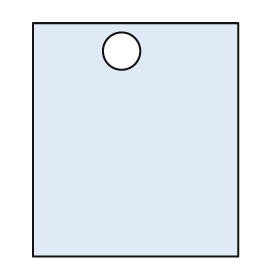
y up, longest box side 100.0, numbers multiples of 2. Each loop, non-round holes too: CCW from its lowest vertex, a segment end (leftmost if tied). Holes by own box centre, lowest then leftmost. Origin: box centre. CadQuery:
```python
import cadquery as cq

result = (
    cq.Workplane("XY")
    .moveTo(-44.0, -50.0)
    .lineTo(44.0, -50.0)
    .lineTo(44.0, 50.0)
    .lineTo(-44.0, 50.0)
    .close()
    .moveTo(-6.0, 38.0)
    .circle(8.0)
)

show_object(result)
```